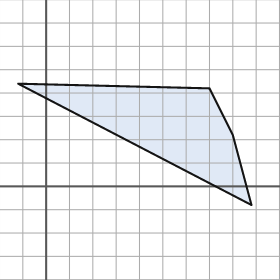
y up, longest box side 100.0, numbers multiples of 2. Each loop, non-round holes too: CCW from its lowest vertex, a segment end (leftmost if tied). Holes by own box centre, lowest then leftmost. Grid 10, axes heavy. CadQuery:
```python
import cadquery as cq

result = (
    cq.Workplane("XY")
    .moveTo(88.0, -8.0)
    .lineTo(80.0, 22.0)
    .lineTo(70.0, 42.0)
    .lineTo(-12.0, 44.0)
    .close()
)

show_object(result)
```